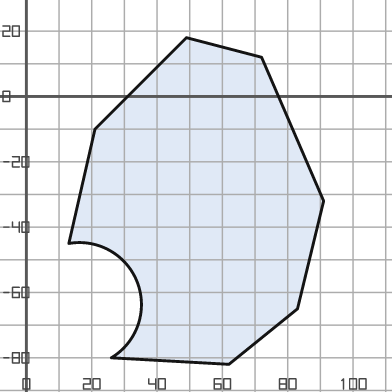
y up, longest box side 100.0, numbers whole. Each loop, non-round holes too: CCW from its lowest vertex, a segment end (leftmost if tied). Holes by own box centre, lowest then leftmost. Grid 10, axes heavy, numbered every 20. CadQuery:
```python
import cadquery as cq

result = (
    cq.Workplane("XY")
    .moveTo(62.0, -82.0)
    .lineTo(83.0, -65.0)
    .lineTo(91.0, -32.0)
    .lineTo(72.0, 12.0)
    .lineTo(49.0, 18.0)
    .lineTo(21.0, -10.0)
    .lineTo(13.0, -45.0)
    .threePointArc((34.0, -57.0), (26.0, -80.0))
    .close()
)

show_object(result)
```